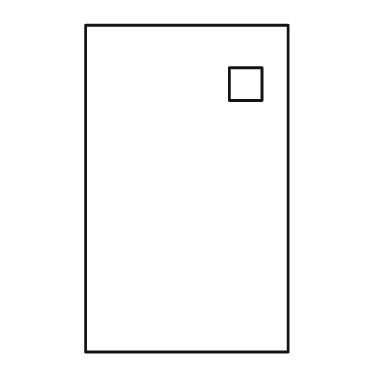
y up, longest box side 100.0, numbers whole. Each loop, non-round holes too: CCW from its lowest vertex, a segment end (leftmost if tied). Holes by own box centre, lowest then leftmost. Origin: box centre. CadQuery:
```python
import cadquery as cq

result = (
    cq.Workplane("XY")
    .moveTo(-31.0, -50.0)
    .lineTo(31.0, -50.0)
    .lineTo(31.0, 50.0)
    .lineTo(-31.0, 50.0)
    .close()
    .moveTo(13.0, 27.0)
    .lineTo(23.0, 27.0)
    .lineTo(23.0, 37.0)
    .lineTo(13.0, 37.0)
    .close()
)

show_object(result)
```